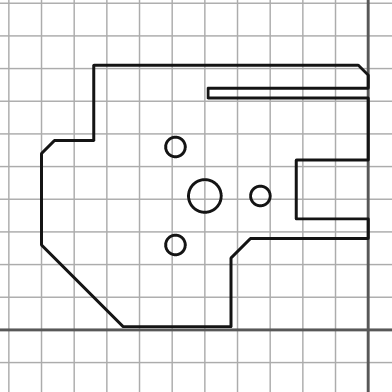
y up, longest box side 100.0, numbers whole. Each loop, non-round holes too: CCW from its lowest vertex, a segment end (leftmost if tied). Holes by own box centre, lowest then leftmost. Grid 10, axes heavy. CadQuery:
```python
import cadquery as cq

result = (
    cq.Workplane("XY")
    .moveTo(-75.0, 1.0)
    .lineTo(-42.0, 1.0)
    .lineTo(-42.0, 22.0)
    .lineTo(-36.0, 28.0)
    .lineTo(0.0, 28.0)
    .lineTo(0.0, 34.0)
    .lineTo(-22.0, 34.0)
    .lineTo(-22.0, 52.0)
    .lineTo(0.0, 52.0)
    .lineTo(0.0, 71.0)
    .lineTo(-49.0, 71.0)
    .lineTo(-49.0, 74.0)
    .lineTo(0.0, 74.0)
    .lineTo(0.0, 78.0)
    .lineTo(-3.0, 81.0)
    .lineTo(-84.0, 81.0)
    .lineTo(-84.0, 58.0)
    .lineTo(-96.0, 58.0)
    .lineTo(-100.0, 54.0)
    .lineTo(-100.0, 26.0)
    .close()
    .moveTo(-59.0, 26.0)
    .circle(3.0)
    .moveTo(-50.0, 41.0)
    .circle(5.0)
    .moveTo(-33.0, 41.0)
    .circle(3.0)
    .moveTo(-59.0, 56.0)
    .circle(3.0)
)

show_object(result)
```